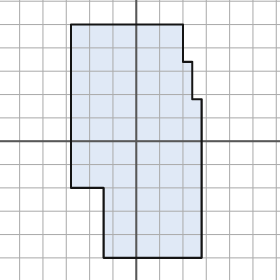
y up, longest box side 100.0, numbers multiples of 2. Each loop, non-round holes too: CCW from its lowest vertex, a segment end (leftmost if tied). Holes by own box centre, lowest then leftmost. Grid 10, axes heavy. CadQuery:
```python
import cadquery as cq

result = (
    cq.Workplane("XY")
    .moveTo(-14.0, -50.0)
    .lineTo(28.0, -50.0)
    .lineTo(28.0, 18.0)
    .lineTo(24.0, 18.0)
    .lineTo(24.0, 34.0)
    .lineTo(20.0, 34.0)
    .lineTo(20.0, 50.0)
    .lineTo(-28.0, 50.0)
    .lineTo(-28.0, -20.0)
    .lineTo(-14.0, -20.0)
    .close()
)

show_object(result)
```